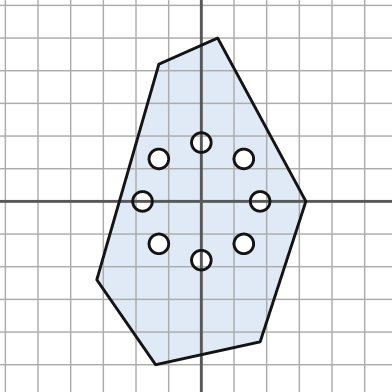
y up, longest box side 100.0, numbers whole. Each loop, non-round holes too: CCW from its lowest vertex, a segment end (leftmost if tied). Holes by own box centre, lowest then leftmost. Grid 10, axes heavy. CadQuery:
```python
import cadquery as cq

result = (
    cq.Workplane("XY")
    .moveTo(-14.0, -50.0)
    .lineTo(18.0, -43.0)
    .lineTo(32.0, 0.0)
    .lineTo(5.0, 50.0)
    .lineTo(-13.0, 42.0)
    .lineTo(-32.0, -24.0)
    .close()
    .moveTo(0.0, -18.0)
    .circle(3.0)
    .moveTo(-13.0, -13.0)
    .circle(3.0)
    .moveTo(13.0, -13.0)
    .circle(3.0)
    .moveTo(-18.0, 0.0)
    .circle(3.0)
    .moveTo(18.0, 0.0)
    .circle(3.0)
    .moveTo(-13.0, 13.0)
    .circle(3.0)
    .moveTo(13.0, 13.0)
    .circle(3.0)
    .moveTo(0.0, 18.0)
    .circle(3.0)
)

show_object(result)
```